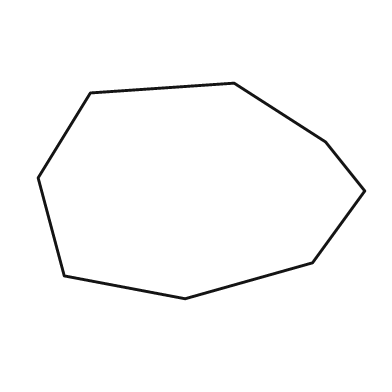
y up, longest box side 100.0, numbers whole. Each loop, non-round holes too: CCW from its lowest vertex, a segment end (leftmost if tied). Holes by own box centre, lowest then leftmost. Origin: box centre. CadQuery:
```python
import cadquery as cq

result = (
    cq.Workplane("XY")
    .moveTo(-5.0, -33.0)
    .lineTo(34.0, -22.0)
    .lineTo(50.0, 0.0)
    .lineTo(38.0, 15.0)
    .lineTo(10.0, 33.0)
    .lineTo(-34.0, 30.0)
    .lineTo(-50.0, 4.0)
    .lineTo(-42.0, -26.0)
    .close()
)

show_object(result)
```